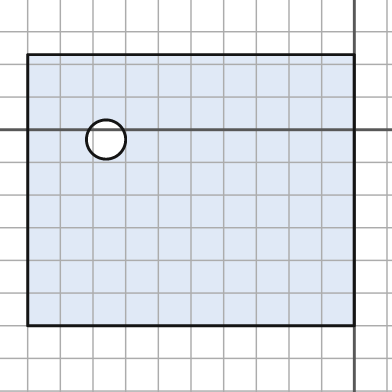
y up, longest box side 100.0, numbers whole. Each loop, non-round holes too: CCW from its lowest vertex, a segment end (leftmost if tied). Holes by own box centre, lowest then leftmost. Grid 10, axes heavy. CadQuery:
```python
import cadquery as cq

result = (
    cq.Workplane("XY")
    .moveTo(-100.0, -60.0)
    .lineTo(0.0, -60.0)
    .lineTo(0.0, 23.0)
    .lineTo(-100.0, 23.0)
    .close()
    .moveTo(-76.0, -3.0)
    .circle(6.0)
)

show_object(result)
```